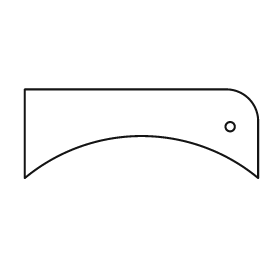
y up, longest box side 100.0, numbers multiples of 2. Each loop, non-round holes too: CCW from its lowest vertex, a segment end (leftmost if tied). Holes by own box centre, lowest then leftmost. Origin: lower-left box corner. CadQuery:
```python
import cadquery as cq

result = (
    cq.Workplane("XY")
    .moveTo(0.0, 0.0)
    .threePointArc((50.0, 18.0), (100.0, 0.0))
    .lineTo(100.0, 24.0)
    .threePointArc((96.0, 34.0), (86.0, 38.0))
    .lineTo(0.0, 38.0)
    .close()
    .moveTo(88.0, 22.0)
    .circle(2.0)
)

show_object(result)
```